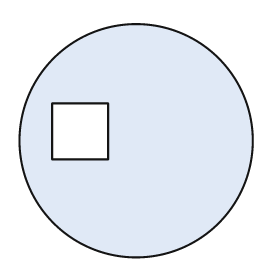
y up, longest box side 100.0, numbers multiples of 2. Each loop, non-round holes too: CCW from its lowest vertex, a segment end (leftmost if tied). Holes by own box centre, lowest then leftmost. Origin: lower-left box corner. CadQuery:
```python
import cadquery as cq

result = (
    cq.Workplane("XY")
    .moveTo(50.0, 50.0)
    .circle(50.0)
    .moveTo(14.0, 42.0)
    .lineTo(38.0, 42.0)
    .lineTo(38.0, 66.0)
    .lineTo(14.0, 66.0)
    .close()
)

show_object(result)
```